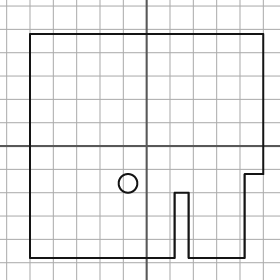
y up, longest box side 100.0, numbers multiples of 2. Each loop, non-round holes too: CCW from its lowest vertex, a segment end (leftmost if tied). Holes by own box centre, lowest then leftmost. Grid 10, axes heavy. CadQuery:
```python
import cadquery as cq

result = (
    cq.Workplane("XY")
    .moveTo(-50.0, -48.0)
    .lineTo(12.0, -48.0)
    .lineTo(12.0, -20.0)
    .lineTo(18.0, -20.0)
    .lineTo(18.0, -48.0)
    .lineTo(42.0, -48.0)
    .lineTo(42.0, -12.0)
    .lineTo(50.0, -12.0)
    .lineTo(50.0, 48.0)
    .lineTo(-50.0, 48.0)
    .close()
    .moveTo(-8.0, -16.0)
    .circle(4.0)
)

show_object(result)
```